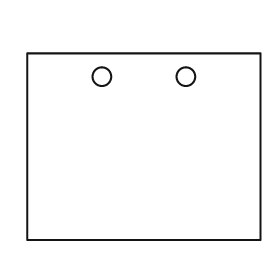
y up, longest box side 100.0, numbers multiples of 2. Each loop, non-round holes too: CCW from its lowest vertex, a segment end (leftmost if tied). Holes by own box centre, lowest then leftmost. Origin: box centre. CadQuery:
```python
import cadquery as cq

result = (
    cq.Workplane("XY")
    .moveTo(-50.0, -40.0)
    .lineTo(50.0, -40.0)
    .lineTo(50.0, 40.0)
    .lineTo(-50.0, 40.0)
    .close()
    .moveTo(-18.0, 30.0)
    .circle(4.0)
    .moveTo(18.0, 30.0)
    .circle(4.0)
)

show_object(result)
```